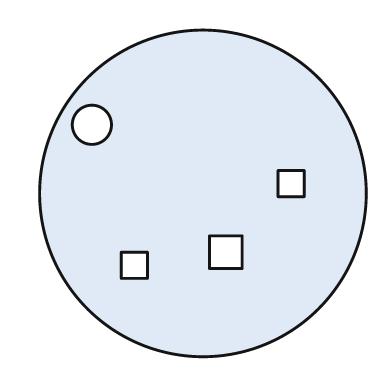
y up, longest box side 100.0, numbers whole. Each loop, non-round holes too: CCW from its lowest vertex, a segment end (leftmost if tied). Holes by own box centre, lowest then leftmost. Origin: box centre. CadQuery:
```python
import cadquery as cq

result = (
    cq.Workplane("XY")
    .moveTo(0.0, 0.0)
    .circle(50.0)
    .moveTo(-25.0, -26.0)
    .lineTo(-17.0, -26.0)
    .lineTo(-17.0, -18.0)
    .lineTo(-25.0, -18.0)
    .close()
    .moveTo(2.0, -23.0)
    .lineTo(12.0, -23.0)
    .lineTo(12.0, -13.0)
    .lineTo(2.0, -13.0)
    .close()
    .moveTo(23.0, -1.0)
    .lineTo(31.0, -1.0)
    .lineTo(31.0, 7.0)
    .lineTo(23.0, 7.0)
    .close()
    .moveTo(-34.0, 21.0)
    .circle(6.0)
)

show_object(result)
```